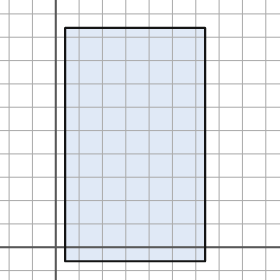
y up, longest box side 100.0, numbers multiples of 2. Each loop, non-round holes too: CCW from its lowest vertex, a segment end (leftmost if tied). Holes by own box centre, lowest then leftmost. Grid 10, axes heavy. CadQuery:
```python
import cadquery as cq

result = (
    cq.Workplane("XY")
    .moveTo(4.0, -6.0)
    .lineTo(64.0, -6.0)
    .lineTo(64.0, 94.0)
    .lineTo(4.0, 94.0)
    .close()
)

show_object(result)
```